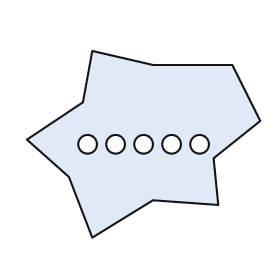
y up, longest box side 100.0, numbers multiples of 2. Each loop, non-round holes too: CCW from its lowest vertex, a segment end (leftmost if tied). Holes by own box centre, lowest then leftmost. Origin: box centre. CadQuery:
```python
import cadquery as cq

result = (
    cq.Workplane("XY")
    .moveTo(-22.0, -40.0)
    .lineTo(4.0, -24.0)
    .lineTo(32.0, -26.0)
    .lineTo(30.0, -6.0)
    .lineTo(50.0, 10.0)
    .lineTo(38.0, 34.0)
    .lineTo(4.0, 34.0)
    .lineTo(-22.0, 40.0)
    .lineTo(-26.0, 18.0)
    .lineTo(-50.0, 2.0)
    .lineTo(-32.0, -14.0)
    .close()
    .moveTo(-24.0, 0.0)
    .circle(4.0)
    .moveTo(-12.0, 0.0)
    .circle(4.0)
    .moveTo(0.0, 0.0)
    .circle(4.0)
    .moveTo(12.0, 0.0)
    .circle(4.0)
    .moveTo(24.0, 0.0)
    .circle(4.0)
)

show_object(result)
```